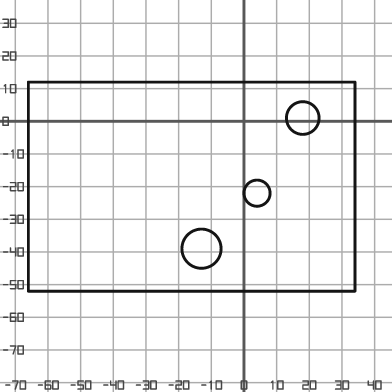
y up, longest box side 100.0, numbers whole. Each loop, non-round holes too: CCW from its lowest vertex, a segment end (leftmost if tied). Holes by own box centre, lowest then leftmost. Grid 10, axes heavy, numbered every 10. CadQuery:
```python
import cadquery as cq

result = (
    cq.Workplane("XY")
    .moveTo(-66.0, -52.0)
    .lineTo(34.0, -52.0)
    .lineTo(34.0, 12.0)
    .lineTo(-66.0, 12.0)
    .close()
    .moveTo(-13.0, -39.0)
    .circle(6.0)
    .moveTo(4.0, -22.0)
    .circle(4.0)
    .moveTo(18.0, 1.0)
    .circle(5.0)
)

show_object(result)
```